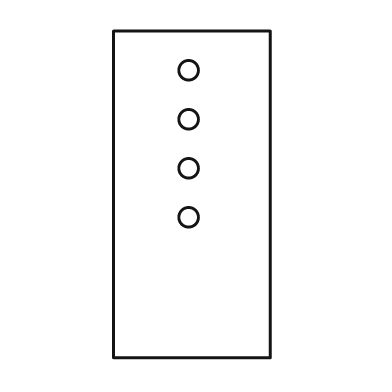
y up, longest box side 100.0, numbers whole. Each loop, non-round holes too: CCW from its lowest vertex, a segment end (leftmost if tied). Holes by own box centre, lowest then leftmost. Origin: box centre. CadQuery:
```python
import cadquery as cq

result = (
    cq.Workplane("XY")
    .moveTo(-24.0, -50.0)
    .lineTo(24.0, -50.0)
    .lineTo(24.0, 50.0)
    .lineTo(-24.0, 50.0)
    .close()
    .moveTo(-1.0, -7.0)
    .circle(3.0)
    .moveTo(-1.0, 8.0)
    .circle(3.0)
    .moveTo(-1.0, 23.0)
    .circle(3.0)
    .moveTo(-1.0, 38.0)
    .circle(3.0)
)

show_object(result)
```